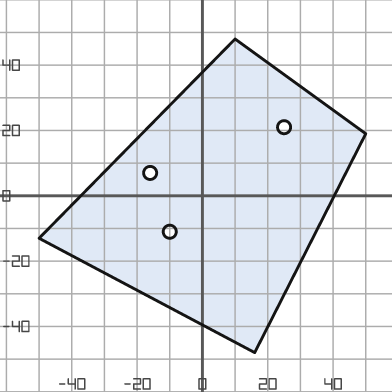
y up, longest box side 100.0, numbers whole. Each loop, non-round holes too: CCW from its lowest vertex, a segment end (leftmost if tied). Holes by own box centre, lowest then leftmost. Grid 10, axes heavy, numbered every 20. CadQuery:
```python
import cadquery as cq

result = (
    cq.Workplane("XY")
    .moveTo(16.0, -48.0)
    .lineTo(50.0, 19.0)
    .lineTo(10.0, 48.0)
    .lineTo(-50.0, -13.0)
    .close()
    .moveTo(-10.0, -11.0)
    .circle(2.0)
    .moveTo(-16.0, 7.0)
    .circle(2.0)
    .moveTo(25.0, 21.0)
    .circle(2.0)
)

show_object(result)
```